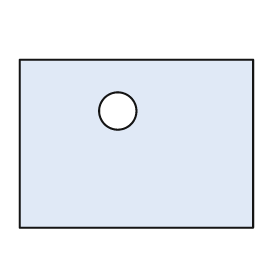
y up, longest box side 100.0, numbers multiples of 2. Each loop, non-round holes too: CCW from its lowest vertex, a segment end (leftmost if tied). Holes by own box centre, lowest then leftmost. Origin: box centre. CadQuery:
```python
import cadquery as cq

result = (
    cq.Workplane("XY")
    .moveTo(-50.0, -36.0)
    .lineTo(50.0, -36.0)
    .lineTo(50.0, 36.0)
    .lineTo(-50.0, 36.0)
    .close()
    .moveTo(-8.0, 14.0)
    .circle(8.0)
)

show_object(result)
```